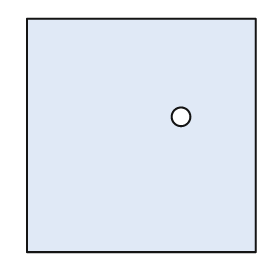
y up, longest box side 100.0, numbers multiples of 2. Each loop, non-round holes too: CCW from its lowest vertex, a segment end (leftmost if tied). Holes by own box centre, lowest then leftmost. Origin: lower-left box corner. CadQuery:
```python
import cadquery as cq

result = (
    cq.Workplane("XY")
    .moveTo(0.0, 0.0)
    .lineTo(98.0, 0.0)
    .lineTo(98.0, 100.0)
    .lineTo(0.0, 100.0)
    .close()
    .moveTo(66.0, 58.0)
    .circle(4.0)
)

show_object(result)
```